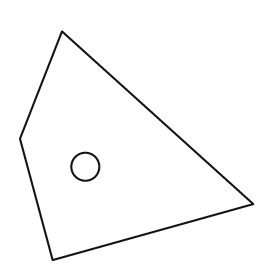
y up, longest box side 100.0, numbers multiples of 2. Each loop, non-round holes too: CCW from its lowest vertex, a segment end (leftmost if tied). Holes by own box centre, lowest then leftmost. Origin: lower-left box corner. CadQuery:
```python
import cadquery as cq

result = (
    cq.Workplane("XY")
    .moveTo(14.0, 0.0)
    .lineTo(100.0, 24.0)
    .lineTo(18.0, 98.0)
    .lineTo(0.0, 52.0)
    .close()
    .moveTo(28.0, 40.0)
    .circle(6.0)
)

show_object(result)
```